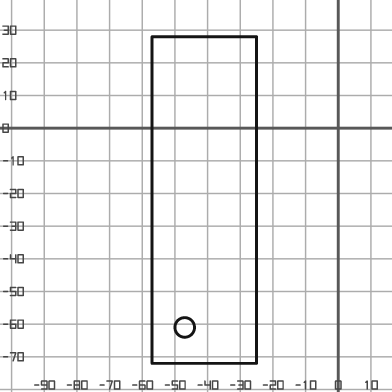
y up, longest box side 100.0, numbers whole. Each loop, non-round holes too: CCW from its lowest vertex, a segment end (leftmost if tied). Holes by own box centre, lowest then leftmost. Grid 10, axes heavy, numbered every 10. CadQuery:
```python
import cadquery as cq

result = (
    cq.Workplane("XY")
    .moveTo(-57.0, -72.0)
    .lineTo(-25.0, -72.0)
    .lineTo(-25.0, 28.0)
    .lineTo(-57.0, 28.0)
    .close()
    .moveTo(-47.0, -61.0)
    .circle(3.0)
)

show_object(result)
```